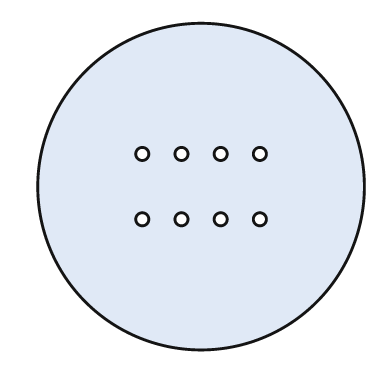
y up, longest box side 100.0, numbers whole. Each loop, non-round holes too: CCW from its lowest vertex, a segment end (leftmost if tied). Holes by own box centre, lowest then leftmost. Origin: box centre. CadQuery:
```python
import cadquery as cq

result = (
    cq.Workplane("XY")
    .moveTo(0.0, 0.0)
    .circle(50.0)
    .moveTo(-18.0, -10.0)
    .circle(2.0)
    .moveTo(-6.0, -10.0)
    .circle(2.0)
    .moveTo(6.0, -10.0)
    .circle(2.0)
    .moveTo(18.0, -10.0)
    .circle(2.0)
    .moveTo(-18.0, 10.0)
    .circle(2.0)
    .moveTo(-6.0, 10.0)
    .circle(2.0)
    .moveTo(6.0, 10.0)
    .circle(2.0)
    .moveTo(18.0, 10.0)
    .circle(2.0)
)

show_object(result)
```